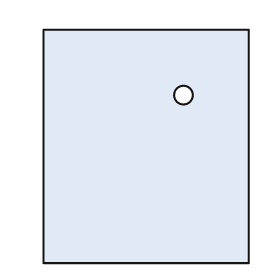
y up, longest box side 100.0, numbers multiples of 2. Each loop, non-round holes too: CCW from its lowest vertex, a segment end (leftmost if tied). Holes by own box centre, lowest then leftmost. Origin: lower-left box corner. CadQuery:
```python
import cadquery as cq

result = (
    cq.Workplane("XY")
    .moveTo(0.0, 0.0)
    .lineTo(88.0, 0.0)
    .lineTo(88.0, 100.0)
    .lineTo(0.0, 100.0)
    .close()
    .moveTo(60.0, 72.0)
    .circle(4.0)
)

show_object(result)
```